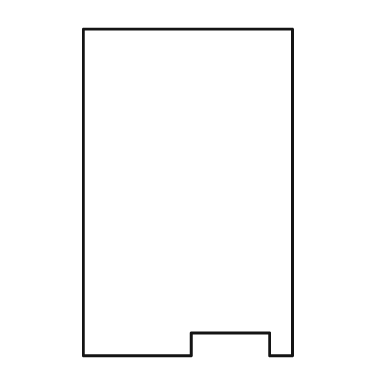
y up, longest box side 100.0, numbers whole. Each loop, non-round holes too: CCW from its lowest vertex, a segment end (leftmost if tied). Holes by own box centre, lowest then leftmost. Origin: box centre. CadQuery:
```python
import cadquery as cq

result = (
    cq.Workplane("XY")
    .moveTo(-32.0, -50.0)
    .lineTo(1.0, -50.0)
    .lineTo(1.0, -43.0)
    .lineTo(25.0, -43.0)
    .lineTo(25.0, -50.0)
    .lineTo(32.0, -50.0)
    .lineTo(32.0, 50.0)
    .lineTo(-32.0, 50.0)
    .close()
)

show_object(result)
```